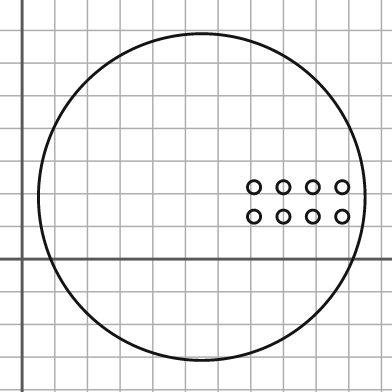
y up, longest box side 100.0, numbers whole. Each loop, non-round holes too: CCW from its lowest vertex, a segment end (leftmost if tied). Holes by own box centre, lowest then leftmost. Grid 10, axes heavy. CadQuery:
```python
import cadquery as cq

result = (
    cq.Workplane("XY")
    .moveTo(55.0, 19.0)
    .circle(50.0)
    .moveTo(71.0, 13.0)
    .circle(2.0)
    .moveTo(80.0, 13.0)
    .circle(2.0)
    .moveTo(89.0, 13.0)
    .circle(2.0)
    .moveTo(98.0, 13.0)
    .circle(2.0)
    .moveTo(71.0, 22.0)
    .circle(2.0)
    .moveTo(80.0, 22.0)
    .circle(2.0)
    .moveTo(89.0, 22.0)
    .circle(2.0)
    .moveTo(98.0, 22.0)
    .circle(2.0)
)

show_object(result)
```